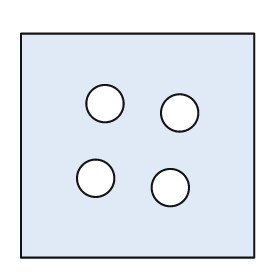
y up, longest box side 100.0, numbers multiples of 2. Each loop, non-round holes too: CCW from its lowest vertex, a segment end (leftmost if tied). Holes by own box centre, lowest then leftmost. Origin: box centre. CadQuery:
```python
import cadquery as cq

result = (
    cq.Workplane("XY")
    .moveTo(-50.0, -48.0)
    .lineTo(50.0, -48.0)
    .lineTo(50.0, 48.0)
    .lineTo(-50.0, 48.0)
    .close()
    .moveTo(14.0, -18.0)
    .circle(8.0)
    .moveTo(-18.0, -14.0)
    .circle(8.0)
    .moveTo(18.0, 14.0)
    .circle(8.0)
    .moveTo(-14.0, 18.0)
    .circle(8.0)
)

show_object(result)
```